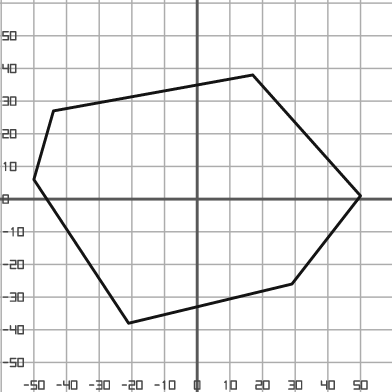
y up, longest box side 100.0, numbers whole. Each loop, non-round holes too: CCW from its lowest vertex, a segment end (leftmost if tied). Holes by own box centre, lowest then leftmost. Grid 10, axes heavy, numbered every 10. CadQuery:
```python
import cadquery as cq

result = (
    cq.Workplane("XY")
    .moveTo(-21.0, -38.0)
    .lineTo(29.0, -26.0)
    .lineTo(50.0, 1.0)
    .lineTo(17.0, 38.0)
    .lineTo(-44.0, 27.0)
    .lineTo(-50.0, 6.0)
    .close()
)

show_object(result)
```